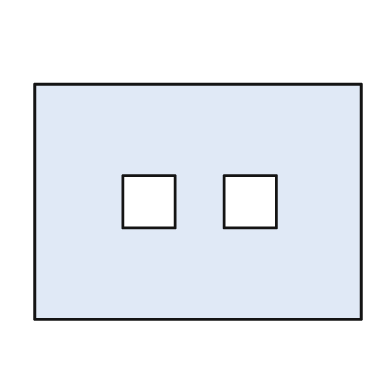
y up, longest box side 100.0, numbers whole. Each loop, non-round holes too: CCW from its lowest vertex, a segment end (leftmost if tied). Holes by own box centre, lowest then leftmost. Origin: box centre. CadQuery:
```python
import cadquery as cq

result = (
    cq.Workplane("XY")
    .moveTo(-50.0, -36.0)
    .lineTo(50.0, -36.0)
    .lineTo(50.0, 36.0)
    .lineTo(-50.0, 36.0)
    .close()
    .moveTo(-23.0, -8.0)
    .lineTo(-7.0, -8.0)
    .lineTo(-7.0, 8.0)
    .lineTo(-23.0, 8.0)
    .close()
    .moveTo(8.0, -8.0)
    .lineTo(24.0, -8.0)
    .lineTo(24.0, 8.0)
    .lineTo(8.0, 8.0)
    .close()
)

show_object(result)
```